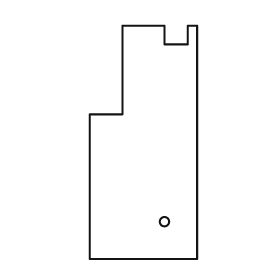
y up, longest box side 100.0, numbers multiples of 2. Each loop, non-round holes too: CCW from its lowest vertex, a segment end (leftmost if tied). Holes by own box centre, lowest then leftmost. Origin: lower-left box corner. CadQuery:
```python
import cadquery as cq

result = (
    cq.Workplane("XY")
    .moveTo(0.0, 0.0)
    .lineTo(46.0, 0.0)
    .lineTo(46.0, 100.0)
    .lineTo(42.0, 100.0)
    .lineTo(42.0, 92.0)
    .lineTo(32.0, 92.0)
    .lineTo(32.0, 100.0)
    .lineTo(14.0, 100.0)
    .lineTo(14.0, 62.0)
    .lineTo(0.0, 62.0)
    .close()
    .moveTo(32.0, 16.0)
    .circle(2.0)
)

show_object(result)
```